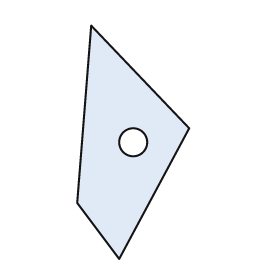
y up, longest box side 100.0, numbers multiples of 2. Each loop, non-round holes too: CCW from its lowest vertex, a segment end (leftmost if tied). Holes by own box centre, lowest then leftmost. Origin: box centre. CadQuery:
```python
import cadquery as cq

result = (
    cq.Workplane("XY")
    .moveTo(-6.0, -50.0)
    .lineTo(24.0, 6.0)
    .lineTo(-18.0, 50.0)
    .lineTo(-24.0, -26.0)
    .close()
    .moveTo(0.0, 0.0)
    .circle(6.0)
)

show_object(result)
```